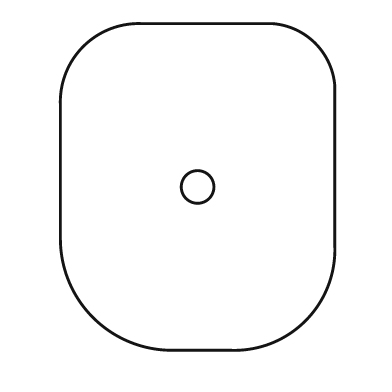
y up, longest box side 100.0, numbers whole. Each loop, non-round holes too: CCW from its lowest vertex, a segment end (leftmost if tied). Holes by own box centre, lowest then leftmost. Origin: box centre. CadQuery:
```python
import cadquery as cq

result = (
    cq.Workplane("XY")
    .moveTo(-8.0, -50.0)
    .lineTo(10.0, -50.0)
    .threePointArc((33.0, -41.0), (42.0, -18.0))
    .lineTo(42.0, 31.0)
    .threePointArc((36.0, 44.0), (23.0, 50.0))
    .lineTo(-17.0, 50.0)
    .threePointArc((-35.0, 43.0), (-42.0, 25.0))
    .lineTo(-42.0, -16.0)
    .threePointArc((-32.0, -40.0), (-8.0, -50.0))
    .close()
    .moveTo(0.0, 0.0)
    .circle(5.0)
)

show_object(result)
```